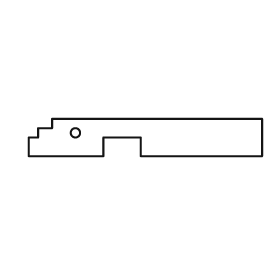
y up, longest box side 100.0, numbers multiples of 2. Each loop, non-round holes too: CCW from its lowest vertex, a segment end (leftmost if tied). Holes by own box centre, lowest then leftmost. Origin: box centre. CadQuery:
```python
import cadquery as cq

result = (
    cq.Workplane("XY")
    .moveTo(-50.0, -8.0)
    .lineTo(-18.0, -8.0)
    .lineTo(-18.0, 0.0)
    .lineTo(-2.0, 0.0)
    .lineTo(-2.0, -8.0)
    .lineTo(50.0, -8.0)
    .lineTo(50.0, 8.0)
    .lineTo(-40.0, 8.0)
    .lineTo(-40.0, 4.0)
    .lineTo(-46.0, 4.0)
    .lineTo(-46.0, 0.0)
    .lineTo(-50.0, 0.0)
    .close()
    .moveTo(-30.0, 2.0)
    .circle(2.0)
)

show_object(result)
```